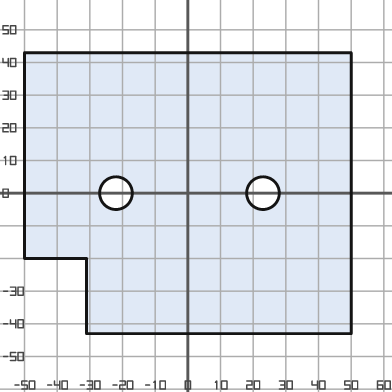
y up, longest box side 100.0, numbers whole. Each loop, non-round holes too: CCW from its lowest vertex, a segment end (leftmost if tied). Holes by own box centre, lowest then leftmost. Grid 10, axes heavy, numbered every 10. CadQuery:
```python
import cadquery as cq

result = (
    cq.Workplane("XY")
    .moveTo(-31.0, -43.0)
    .lineTo(50.0, -43.0)
    .lineTo(50.0, 43.0)
    .lineTo(-50.0, 43.0)
    .lineTo(-50.0, -20.0)
    .lineTo(-31.0, -20.0)
    .close()
    .moveTo(-22.0, 0.0)
    .circle(5.0)
    .moveTo(23.0, 0.0)
    .circle(5.0)
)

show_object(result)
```